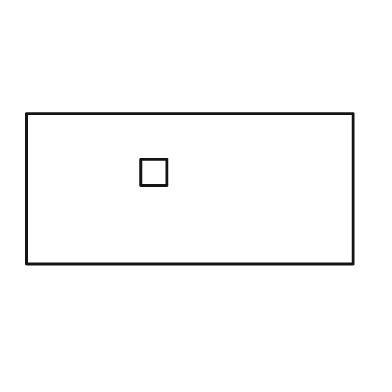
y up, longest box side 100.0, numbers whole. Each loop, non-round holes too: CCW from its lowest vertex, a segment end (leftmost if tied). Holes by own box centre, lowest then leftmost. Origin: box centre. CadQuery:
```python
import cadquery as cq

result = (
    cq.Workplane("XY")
    .moveTo(-50.0, -23.0)
    .lineTo(50.0, -23.0)
    .lineTo(50.0, 23.0)
    .lineTo(-50.0, 23.0)
    .close()
    .moveTo(-15.0, 1.0)
    .lineTo(-7.0, 1.0)
    .lineTo(-7.0, 9.0)
    .lineTo(-15.0, 9.0)
    .close()
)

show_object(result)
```